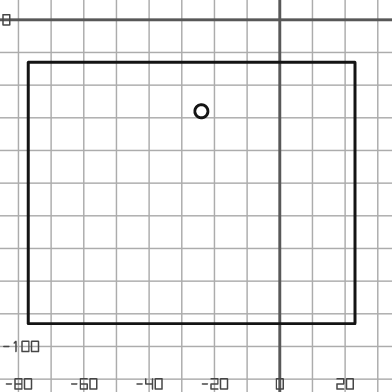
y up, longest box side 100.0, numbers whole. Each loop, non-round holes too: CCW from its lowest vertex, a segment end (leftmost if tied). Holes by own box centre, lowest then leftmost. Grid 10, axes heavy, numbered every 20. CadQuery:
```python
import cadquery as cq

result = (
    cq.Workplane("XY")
    .moveTo(-77.0, -93.0)
    .lineTo(23.0, -93.0)
    .lineTo(23.0, -13.0)
    .lineTo(-77.0, -13.0)
    .close()
    .moveTo(-24.0, -28.0)
    .circle(2.0)
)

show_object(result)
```